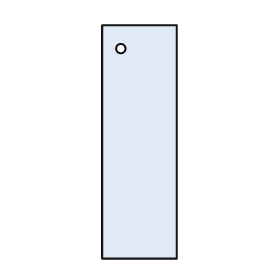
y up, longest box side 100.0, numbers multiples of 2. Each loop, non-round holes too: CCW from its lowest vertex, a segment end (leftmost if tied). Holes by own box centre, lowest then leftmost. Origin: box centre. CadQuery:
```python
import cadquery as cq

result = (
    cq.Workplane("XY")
    .moveTo(-16.0, -50.0)
    .lineTo(16.0, -50.0)
    .lineTo(16.0, 50.0)
    .lineTo(-16.0, 50.0)
    .close()
    .moveTo(-8.0, 40.0)
    .circle(2.0)
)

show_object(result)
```